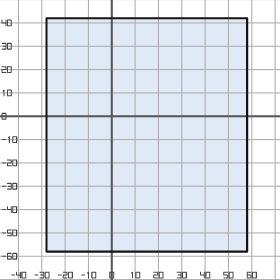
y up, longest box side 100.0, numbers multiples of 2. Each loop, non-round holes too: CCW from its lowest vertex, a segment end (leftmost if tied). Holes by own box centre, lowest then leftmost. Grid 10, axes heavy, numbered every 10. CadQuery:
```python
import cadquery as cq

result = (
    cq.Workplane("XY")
    .moveTo(-28.0, -58.0)
    .lineTo(58.0, -58.0)
    .lineTo(58.0, 42.0)
    .lineTo(-28.0, 42.0)
    .close()
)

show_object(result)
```